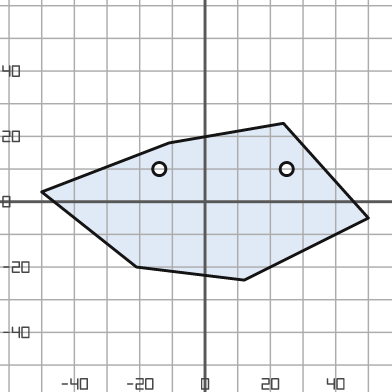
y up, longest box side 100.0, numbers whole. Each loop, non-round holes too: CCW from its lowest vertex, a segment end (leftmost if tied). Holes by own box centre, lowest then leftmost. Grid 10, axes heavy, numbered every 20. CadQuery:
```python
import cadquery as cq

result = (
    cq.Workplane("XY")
    .moveTo(12.0, -24.0)
    .lineTo(50.0, -5.0)
    .lineTo(24.0, 24.0)
    .lineTo(-11.0, 18.0)
    .lineTo(-50.0, 3.0)
    .lineTo(-21.0, -20.0)
    .close()
    .moveTo(-14.0, 10.0)
    .circle(2.0)
    .moveTo(25.0, 10.0)
    .circle(2.0)
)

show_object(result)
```